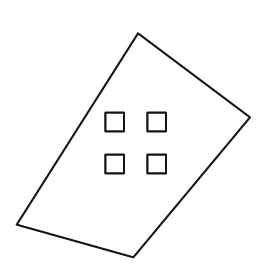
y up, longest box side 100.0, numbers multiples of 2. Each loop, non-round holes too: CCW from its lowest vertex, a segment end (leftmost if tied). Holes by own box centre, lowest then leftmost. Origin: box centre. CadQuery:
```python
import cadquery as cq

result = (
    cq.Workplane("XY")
    .moveTo(0.0, -48.0)
    .lineTo(50.0, 12.0)
    .lineTo(2.0, 48.0)
    .lineTo(-50.0, -34.0)
    .close()
    .moveTo(-12.0, -12.0)
    .lineTo(-4.0, -12.0)
    .lineTo(-4.0, -4.0)
    .lineTo(-12.0, -4.0)
    .close()
    .moveTo(6.0, -12.0)
    .lineTo(14.0, -12.0)
    .lineTo(14.0, -4.0)
    .lineTo(6.0, -4.0)
    .close()
    .moveTo(-12.0, 6.0)
    .lineTo(-4.0, 6.0)
    .lineTo(-4.0, 14.0)
    .lineTo(-12.0, 14.0)
    .close()
    .moveTo(6.0, 6.0)
    .lineTo(14.0, 6.0)
    .lineTo(14.0, 14.0)
    .lineTo(6.0, 14.0)
    .close()
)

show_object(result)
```